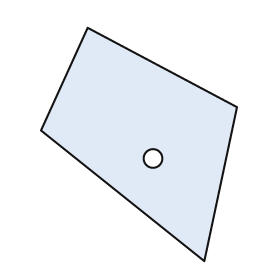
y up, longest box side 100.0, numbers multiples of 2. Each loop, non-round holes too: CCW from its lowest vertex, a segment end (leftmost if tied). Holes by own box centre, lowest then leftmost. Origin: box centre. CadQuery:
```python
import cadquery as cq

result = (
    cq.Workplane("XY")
    .moveTo(28.0, -50.0)
    .lineTo(42.0, 16.0)
    .lineTo(-22.0, 50.0)
    .lineTo(-42.0, 6.0)
    .close()
    .moveTo(6.0, -6.0)
    .circle(4.0)
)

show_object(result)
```